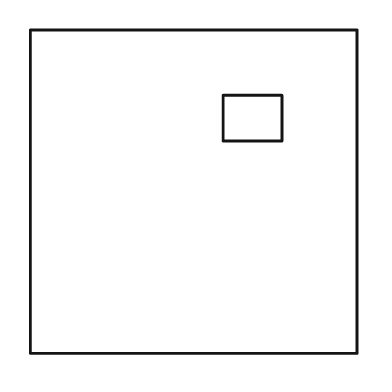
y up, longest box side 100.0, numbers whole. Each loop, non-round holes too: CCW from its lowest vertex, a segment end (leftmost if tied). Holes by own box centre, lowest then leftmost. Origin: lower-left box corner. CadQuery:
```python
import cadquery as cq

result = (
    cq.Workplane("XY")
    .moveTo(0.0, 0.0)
    .lineTo(100.0, 0.0)
    .lineTo(100.0, 99.0)
    .lineTo(0.0, 99.0)
    .close()
    .moveTo(59.0, 65.0)
    .lineTo(77.0, 65.0)
    .lineTo(77.0, 79.0)
    .lineTo(59.0, 79.0)
    .close()
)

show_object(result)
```